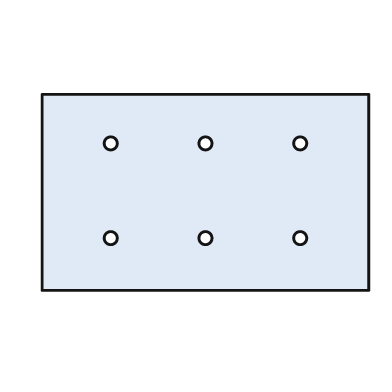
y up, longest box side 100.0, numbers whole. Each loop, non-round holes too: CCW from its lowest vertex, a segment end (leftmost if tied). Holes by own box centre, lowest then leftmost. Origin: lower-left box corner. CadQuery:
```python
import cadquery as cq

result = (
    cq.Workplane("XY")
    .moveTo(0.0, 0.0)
    .lineTo(100.0, 0.0)
    .lineTo(100.0, 60.0)
    .lineTo(0.0, 60.0)
    .close()
    .moveTo(21.0, 16.0)
    .circle(2.0)
    .moveTo(50.0, 16.0)
    .circle(2.0)
    .moveTo(79.0, 16.0)
    .circle(2.0)
    .moveTo(21.0, 45.0)
    .circle(2.0)
    .moveTo(50.0, 45.0)
    .circle(2.0)
    .moveTo(79.0, 45.0)
    .circle(2.0)
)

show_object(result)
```